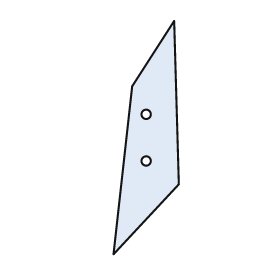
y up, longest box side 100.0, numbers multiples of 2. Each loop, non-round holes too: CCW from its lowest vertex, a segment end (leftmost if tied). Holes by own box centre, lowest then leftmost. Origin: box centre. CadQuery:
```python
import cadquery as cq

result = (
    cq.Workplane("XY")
    .moveTo(-14.0, -50.0)
    .lineTo(14.0, -20.0)
    .lineTo(12.0, 50.0)
    .lineTo(-6.0, 22.0)
    .close()
    .moveTo(0.0, -10.0)
    .circle(2.0)
    .moveTo(0.0, 10.0)
    .circle(2.0)
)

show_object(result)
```